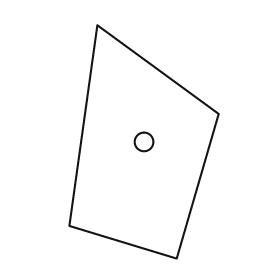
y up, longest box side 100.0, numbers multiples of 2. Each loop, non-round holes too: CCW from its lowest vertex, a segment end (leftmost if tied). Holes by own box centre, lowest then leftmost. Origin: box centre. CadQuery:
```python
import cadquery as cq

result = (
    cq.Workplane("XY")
    .moveTo(14.0, -50.0)
    .lineTo(32.0, 12.0)
    .lineTo(-20.0, 50.0)
    .lineTo(-32.0, -36.0)
    .close()
    .moveTo(0.0, 0.0)
    .circle(4.0)
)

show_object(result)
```